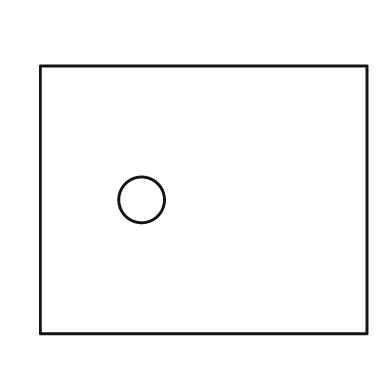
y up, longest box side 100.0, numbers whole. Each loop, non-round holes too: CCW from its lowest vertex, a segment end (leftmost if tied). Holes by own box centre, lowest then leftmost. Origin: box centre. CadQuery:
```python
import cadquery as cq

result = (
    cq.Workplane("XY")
    .moveTo(-50.0, -41.0)
    .lineTo(50.0, -41.0)
    .lineTo(50.0, 41.0)
    .lineTo(-50.0, 41.0)
    .close()
    .moveTo(-19.0, 0.0)
    .circle(7.0)
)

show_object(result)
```